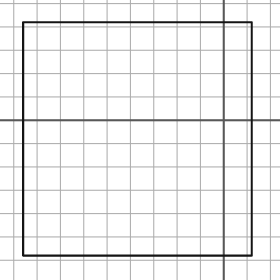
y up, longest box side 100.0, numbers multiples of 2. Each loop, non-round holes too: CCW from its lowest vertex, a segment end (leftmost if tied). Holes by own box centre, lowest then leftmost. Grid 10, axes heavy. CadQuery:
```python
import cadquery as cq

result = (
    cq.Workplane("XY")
    .moveTo(-86.0, -58.0)
    .lineTo(12.0, -58.0)
    .lineTo(12.0, 42.0)
    .lineTo(-86.0, 42.0)
    .close()
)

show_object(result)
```